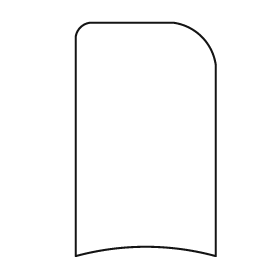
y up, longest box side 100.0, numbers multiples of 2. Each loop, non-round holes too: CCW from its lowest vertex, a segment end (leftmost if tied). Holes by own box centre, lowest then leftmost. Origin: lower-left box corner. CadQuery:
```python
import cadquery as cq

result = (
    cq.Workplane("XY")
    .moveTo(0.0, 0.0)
    .threePointArc((30.0, 4.0), (60.0, 0.0))
    .lineTo(60.0, 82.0)
    .threePointArc((54.0, 94.0), (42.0, 100.0))
    .lineTo(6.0, 100.0)
    .threePointArc((2.0, 98.0), (0.0, 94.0))
    .close()
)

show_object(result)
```